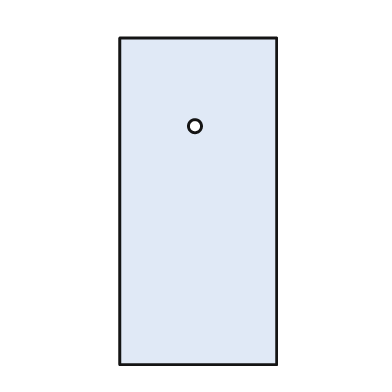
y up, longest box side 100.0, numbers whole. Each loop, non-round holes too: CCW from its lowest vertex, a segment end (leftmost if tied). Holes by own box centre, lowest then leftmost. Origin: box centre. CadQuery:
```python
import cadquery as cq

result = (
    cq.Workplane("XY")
    .moveTo(-24.0, -50.0)
    .lineTo(24.0, -50.0)
    .lineTo(24.0, 50.0)
    .lineTo(-24.0, 50.0)
    .close()
    .moveTo(-1.0, 23.0)
    .circle(2.0)
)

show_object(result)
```